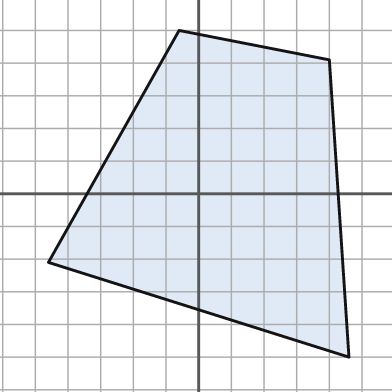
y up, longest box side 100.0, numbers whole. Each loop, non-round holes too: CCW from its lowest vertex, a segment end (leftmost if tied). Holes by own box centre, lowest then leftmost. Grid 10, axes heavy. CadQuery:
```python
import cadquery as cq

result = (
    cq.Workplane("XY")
    .moveTo(46.0, -50.0)
    .lineTo(40.0, 41.0)
    .lineTo(-6.0, 50.0)
    .lineTo(-46.0, -21.0)
    .close()
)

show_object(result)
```